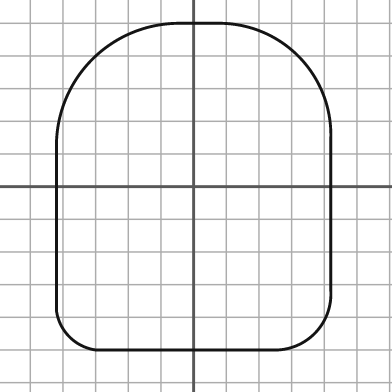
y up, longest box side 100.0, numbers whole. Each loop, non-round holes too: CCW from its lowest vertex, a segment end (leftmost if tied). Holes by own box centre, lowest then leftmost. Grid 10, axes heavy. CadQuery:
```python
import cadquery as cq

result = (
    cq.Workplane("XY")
    .moveTo(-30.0, -50.0)
    .lineTo(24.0, -50.0)
    .threePointArc((37.0, -45.0), (42.0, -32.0))
    .lineTo(42.0, 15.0)
    .threePointArc((32.0, 40.0), (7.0, 50.0))
    .lineTo(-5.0, 50.0)
    .threePointArc((-31.0, 39.0), (-42.0, 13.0))
    .lineTo(-42.0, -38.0)
    .threePointArc((-38.0, -46.0), (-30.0, -50.0))
    .close()
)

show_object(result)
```